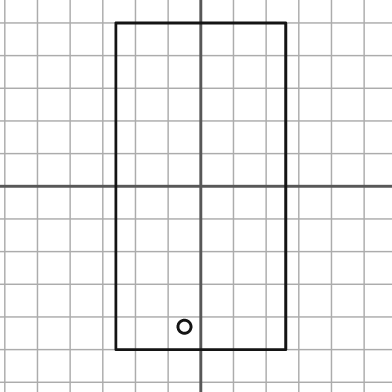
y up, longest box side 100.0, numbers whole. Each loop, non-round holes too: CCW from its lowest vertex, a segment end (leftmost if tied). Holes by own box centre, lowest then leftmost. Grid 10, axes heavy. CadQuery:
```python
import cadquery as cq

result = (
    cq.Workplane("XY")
    .moveTo(-26.0, -50.0)
    .lineTo(26.0, -50.0)
    .lineTo(26.0, 50.0)
    .lineTo(-26.0, 50.0)
    .close()
    .moveTo(-5.0, -43.0)
    .circle(2.0)
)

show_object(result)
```